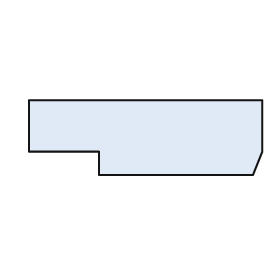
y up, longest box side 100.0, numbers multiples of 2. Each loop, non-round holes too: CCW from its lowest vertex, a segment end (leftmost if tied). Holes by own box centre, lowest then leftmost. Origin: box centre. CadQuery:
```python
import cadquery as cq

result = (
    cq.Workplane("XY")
    .moveTo(-20.0, -16.0)
    .lineTo(46.0, -16.0)
    .lineTo(50.0, -6.0)
    .lineTo(50.0, 16.0)
    .lineTo(-50.0, 16.0)
    .lineTo(-50.0, -6.0)
    .lineTo(-20.0, -6.0)
    .close()
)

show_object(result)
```